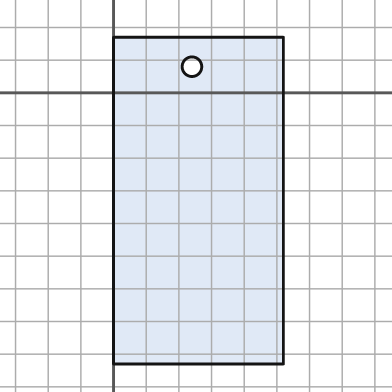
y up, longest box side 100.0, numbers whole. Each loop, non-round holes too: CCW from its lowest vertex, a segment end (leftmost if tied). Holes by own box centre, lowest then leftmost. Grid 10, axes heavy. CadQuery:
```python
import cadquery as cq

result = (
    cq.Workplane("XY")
    .moveTo(0.0, -83.0)
    .lineTo(52.0, -83.0)
    .lineTo(52.0, 17.0)
    .lineTo(0.0, 17.0)
    .close()
    .moveTo(24.0, 8.0)
    .circle(3.0)
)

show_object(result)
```